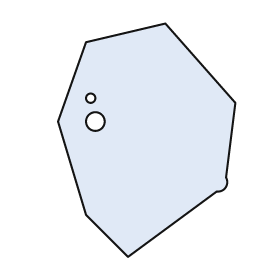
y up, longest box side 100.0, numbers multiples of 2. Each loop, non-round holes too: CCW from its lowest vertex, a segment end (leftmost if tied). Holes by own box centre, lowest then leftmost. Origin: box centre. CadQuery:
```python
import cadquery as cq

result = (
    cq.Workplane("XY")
    .moveTo(-8.0, -50.0)
    .lineTo(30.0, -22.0)
    .threePointArc((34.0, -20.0), (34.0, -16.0))
    .lineTo(38.0, 16.0)
    .lineTo(8.0, 50.0)
    .lineTo(-26.0, 42.0)
    .lineTo(-38.0, 8.0)
    .lineTo(-26.0, -32.0)
    .close()
    .moveTo(-22.0, 8.0)
    .circle(4.0)
    .moveTo(-24.0, 18.0)
    .circle(2.0)
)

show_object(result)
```